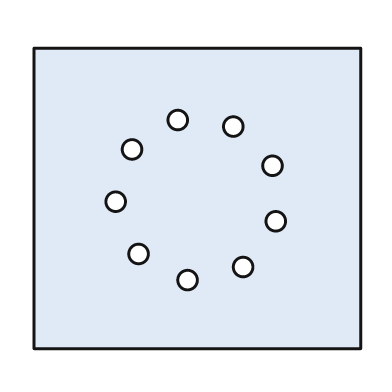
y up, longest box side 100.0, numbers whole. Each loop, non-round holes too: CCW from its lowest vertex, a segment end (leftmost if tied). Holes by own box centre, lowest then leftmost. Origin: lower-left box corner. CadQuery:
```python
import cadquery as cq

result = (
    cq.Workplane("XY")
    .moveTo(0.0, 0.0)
    .lineTo(100.0, 0.0)
    .lineTo(100.0, 92.0)
    .lineTo(0.0, 92.0)
    .close()
    .moveTo(47.0, 21.0)
    .circle(3.0)
    .moveTo(64.0, 25.0)
    .circle(3.0)
    .moveTo(32.0, 29.0)
    .circle(3.0)
    .moveTo(74.0, 39.0)
    .circle(3.0)
    .moveTo(25.0, 45.0)
    .circle(3.0)
    .moveTo(73.0, 56.0)
    .circle(3.0)
    .moveTo(30.0, 61.0)
    .circle(3.0)
    .moveTo(61.0, 68.0)
    .circle(3.0)
    .moveTo(44.0, 70.0)
    .circle(3.0)
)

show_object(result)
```